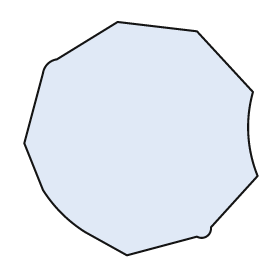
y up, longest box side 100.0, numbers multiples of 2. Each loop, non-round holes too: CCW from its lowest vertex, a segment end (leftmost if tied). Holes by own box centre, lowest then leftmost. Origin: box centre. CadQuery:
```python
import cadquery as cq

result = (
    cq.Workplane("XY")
    .moveTo(-6.0, -50.0)
    .lineTo(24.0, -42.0)
    .threePointArc((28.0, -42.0), (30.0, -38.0))
    .lineTo(50.0, -16.0)
    .threePointArc((46.0, 2.0), (48.0, 20.0))
    .lineTo(24.0, 46.0)
    .lineTo(-10.0, 50.0)
    .lineTo(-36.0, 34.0)
    .threePointArc((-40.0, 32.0), (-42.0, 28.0))
    .lineTo(-50.0, -2.0)
    .lineTo(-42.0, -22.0)
    .threePointArc((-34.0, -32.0), (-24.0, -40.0))
    .close()
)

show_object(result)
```